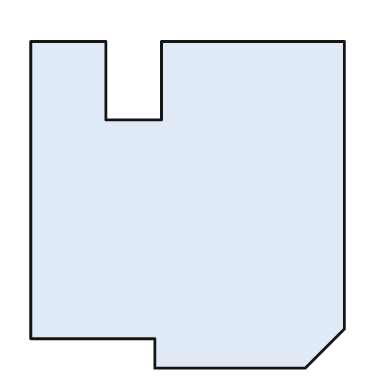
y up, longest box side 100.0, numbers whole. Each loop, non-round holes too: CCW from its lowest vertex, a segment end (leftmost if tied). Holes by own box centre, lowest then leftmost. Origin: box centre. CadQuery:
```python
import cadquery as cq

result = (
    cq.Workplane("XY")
    .moveTo(-10.0, -50.0)
    .lineTo(36.0, -50.0)
    .lineTo(48.0, -38.0)
    .lineTo(48.0, 50.0)
    .lineTo(-8.0, 50.0)
    .lineTo(-8.0, 26.0)
    .lineTo(-25.0, 26.0)
    .lineTo(-25.0, 50.0)
    .lineTo(-48.0, 50.0)
    .lineTo(-48.0, -41.0)
    .lineTo(-10.0, -41.0)
    .close()
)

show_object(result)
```